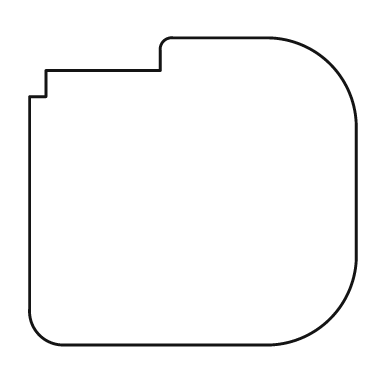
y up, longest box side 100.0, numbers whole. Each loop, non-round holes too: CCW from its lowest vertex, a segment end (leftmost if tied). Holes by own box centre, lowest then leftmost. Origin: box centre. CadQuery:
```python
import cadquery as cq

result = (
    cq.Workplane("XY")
    .moveTo(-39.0, -47.0)
    .lineTo(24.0, -47.0)
    .threePointArc((42.0, -39.0), (50.0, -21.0))
    .lineTo(50.0, 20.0)
    .threePointArc((42.0, 39.0), (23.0, 47.0))
    .lineTo(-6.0, 47.0)
    .threePointArc((-9.0, 46.0), (-10.0, 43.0))
    .lineTo(-10.0, 37.0)
    .lineTo(-45.0, 37.0)
    .lineTo(-45.0, 29.0)
    .lineTo(-50.0, 29.0)
    .lineTo(-50.0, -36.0)
    .threePointArc((-47.0, -44.0), (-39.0, -47.0))
    .close()
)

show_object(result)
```